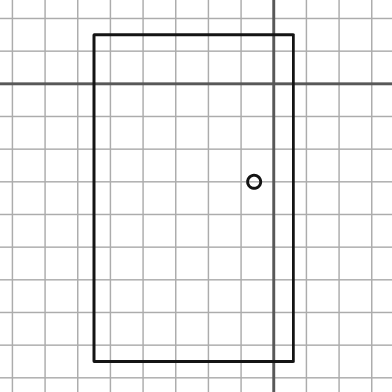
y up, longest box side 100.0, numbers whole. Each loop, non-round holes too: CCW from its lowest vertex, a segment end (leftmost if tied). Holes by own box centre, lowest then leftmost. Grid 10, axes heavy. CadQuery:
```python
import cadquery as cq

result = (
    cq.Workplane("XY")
    .moveTo(-55.0, -85.0)
    .lineTo(6.0, -85.0)
    .lineTo(6.0, 15.0)
    .lineTo(-55.0, 15.0)
    .close()
    .moveTo(-6.0, -30.0)
    .circle(2.0)
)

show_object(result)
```